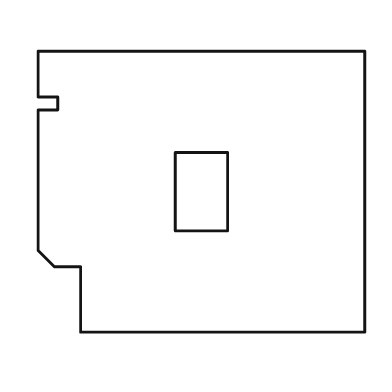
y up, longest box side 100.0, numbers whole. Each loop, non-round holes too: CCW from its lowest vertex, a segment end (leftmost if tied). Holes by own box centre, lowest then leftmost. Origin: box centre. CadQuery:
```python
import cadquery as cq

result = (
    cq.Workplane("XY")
    .moveTo(-37.0, -43.0)
    .lineTo(50.0, -43.0)
    .lineTo(50.0, 43.0)
    .lineTo(-50.0, 43.0)
    .lineTo(-50.0, 29.0)
    .lineTo(-44.0, 29.0)
    .lineTo(-44.0, 25.0)
    .lineTo(-50.0, 25.0)
    .lineTo(-50.0, -18.0)
    .lineTo(-45.0, -23.0)
    .lineTo(-37.0, -23.0)
    .close()
    .moveTo(-8.0, -12.0)
    .lineTo(8.0, -12.0)
    .lineTo(8.0, 12.0)
    .lineTo(-8.0, 12.0)
    .close()
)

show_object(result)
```